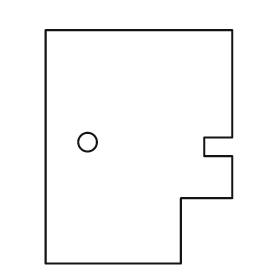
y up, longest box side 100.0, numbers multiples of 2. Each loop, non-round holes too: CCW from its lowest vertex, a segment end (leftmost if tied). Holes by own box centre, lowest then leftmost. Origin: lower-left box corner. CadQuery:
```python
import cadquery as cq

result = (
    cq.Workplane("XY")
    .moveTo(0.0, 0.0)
    .lineTo(58.0, 0.0)
    .lineTo(58.0, 28.0)
    .lineTo(80.0, 28.0)
    .lineTo(80.0, 46.0)
    .lineTo(68.0, 46.0)
    .lineTo(68.0, 54.0)
    .lineTo(80.0, 54.0)
    .lineTo(80.0, 100.0)
    .lineTo(0.0, 100.0)
    .close()
    .moveTo(18.0, 52.0)
    .circle(4.0)
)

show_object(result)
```